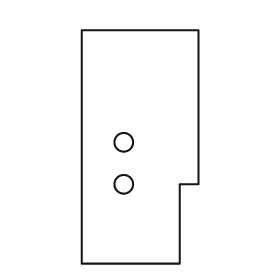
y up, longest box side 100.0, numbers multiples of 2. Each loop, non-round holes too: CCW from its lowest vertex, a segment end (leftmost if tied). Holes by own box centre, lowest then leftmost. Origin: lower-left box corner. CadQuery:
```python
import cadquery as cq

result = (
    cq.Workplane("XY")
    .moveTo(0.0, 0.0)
    .lineTo(42.0, 0.0)
    .lineTo(42.0, 34.0)
    .lineTo(50.0, 34.0)
    .lineTo(50.0, 100.0)
    .lineTo(0.0, 100.0)
    .close()
    .moveTo(18.0, 34.0)
    .circle(4.0)
    .moveTo(18.0, 52.0)
    .circle(4.0)
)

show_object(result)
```